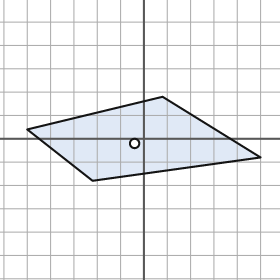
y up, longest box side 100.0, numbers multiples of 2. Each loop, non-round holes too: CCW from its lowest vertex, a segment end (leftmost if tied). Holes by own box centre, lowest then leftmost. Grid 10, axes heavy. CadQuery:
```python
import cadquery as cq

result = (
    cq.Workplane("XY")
    .moveTo(-22.0, -18.0)
    .lineTo(50.0, -8.0)
    .lineTo(8.0, 18.0)
    .lineTo(-50.0, 4.0)
    .close()
    .moveTo(-4.0, -2.0)
    .circle(2.0)
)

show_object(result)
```